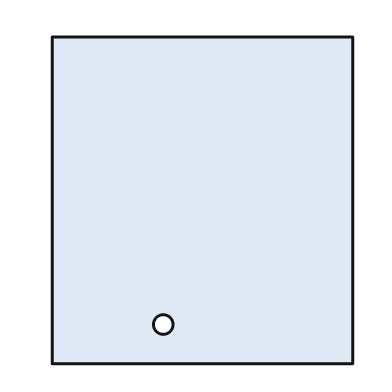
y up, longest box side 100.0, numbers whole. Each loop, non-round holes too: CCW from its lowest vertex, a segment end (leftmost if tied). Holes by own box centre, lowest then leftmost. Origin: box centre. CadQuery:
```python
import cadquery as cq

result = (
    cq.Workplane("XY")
    .moveTo(-46.0, -50.0)
    .lineTo(46.0, -50.0)
    .lineTo(46.0, 50.0)
    .lineTo(-46.0, 50.0)
    .close()
    .moveTo(-12.0, -38.0)
    .circle(3.0)
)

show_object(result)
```